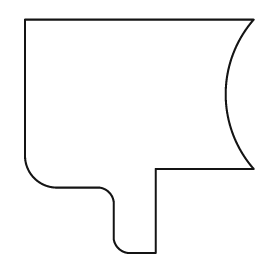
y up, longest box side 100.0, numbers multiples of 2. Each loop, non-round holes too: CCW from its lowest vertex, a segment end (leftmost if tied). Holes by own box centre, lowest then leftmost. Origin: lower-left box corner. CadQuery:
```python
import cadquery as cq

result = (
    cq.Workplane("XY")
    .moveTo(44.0, 0.0)
    .lineTo(56.0, 0.0)
    .lineTo(56.0, 36.0)
    .lineTo(98.0, 36.0)
    .threePointArc((86.0, 68.0), (98.0, 100.0))
    .lineTo(0.0, 100.0)
    .lineTo(0.0, 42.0)
    .threePointArc((4.0, 32.0), (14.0, 28.0))
    .lineTo(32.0, 28.0)
    .threePointArc((36.0, 26.0), (38.0, 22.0))
    .lineTo(38.0, 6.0)
    .threePointArc((40.0, 2.0), (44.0, 0.0))
    .close()
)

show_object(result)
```